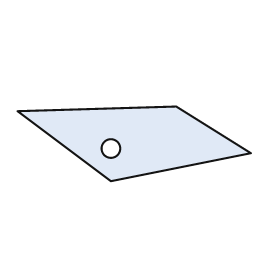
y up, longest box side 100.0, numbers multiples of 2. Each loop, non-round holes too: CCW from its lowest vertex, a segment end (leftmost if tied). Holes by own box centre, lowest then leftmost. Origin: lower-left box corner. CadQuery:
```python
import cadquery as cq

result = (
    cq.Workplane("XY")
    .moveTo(40.0, 0.0)
    .lineTo(100.0, 12.0)
    .lineTo(68.0, 32.0)
    .lineTo(0.0, 30.0)
    .close()
    .moveTo(40.0, 14.0)
    .circle(4.0)
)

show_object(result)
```